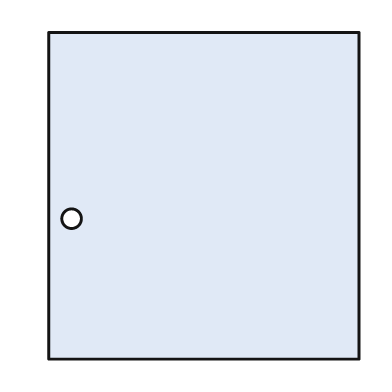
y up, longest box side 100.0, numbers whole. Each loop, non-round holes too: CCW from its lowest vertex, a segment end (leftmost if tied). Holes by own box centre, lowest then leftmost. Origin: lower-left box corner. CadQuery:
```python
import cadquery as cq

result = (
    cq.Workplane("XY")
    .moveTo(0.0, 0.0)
    .lineTo(95.0, 0.0)
    .lineTo(95.0, 100.0)
    .lineTo(0.0, 100.0)
    .close()
    .moveTo(7.0, 43.0)
    .circle(3.0)
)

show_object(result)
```